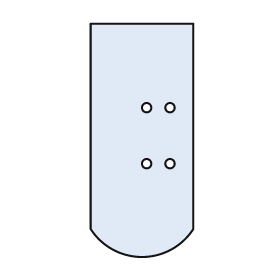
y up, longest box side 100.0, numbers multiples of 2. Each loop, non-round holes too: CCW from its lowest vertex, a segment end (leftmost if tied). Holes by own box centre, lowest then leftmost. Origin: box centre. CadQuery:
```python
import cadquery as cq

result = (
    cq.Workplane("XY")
    .moveTo(-22.0, -38.0)
    .threePointArc((0.0, -50.0), (22.0, -38.0))
    .lineTo(22.0, 50.0)
    .lineTo(-22.0, 50.0)
    .close()
    .moveTo(2.0, -10.0)
    .circle(2.0)
    .moveTo(12.0, -10.0)
    .circle(2.0)
    .moveTo(2.0, 14.0)
    .circle(2.0)
    .moveTo(12.0, 14.0)
    .circle(2.0)
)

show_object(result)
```